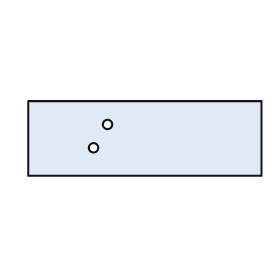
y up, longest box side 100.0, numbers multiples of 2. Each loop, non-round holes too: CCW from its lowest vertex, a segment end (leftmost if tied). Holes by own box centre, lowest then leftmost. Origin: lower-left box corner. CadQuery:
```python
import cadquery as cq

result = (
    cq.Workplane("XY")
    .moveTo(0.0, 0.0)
    .lineTo(100.0, 0.0)
    .lineTo(100.0, 32.0)
    .lineTo(0.0, 32.0)
    .close()
    .moveTo(28.0, 12.0)
    .circle(2.0)
    .moveTo(34.0, 22.0)
    .circle(2.0)
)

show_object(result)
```